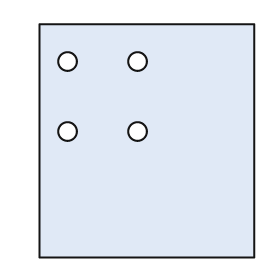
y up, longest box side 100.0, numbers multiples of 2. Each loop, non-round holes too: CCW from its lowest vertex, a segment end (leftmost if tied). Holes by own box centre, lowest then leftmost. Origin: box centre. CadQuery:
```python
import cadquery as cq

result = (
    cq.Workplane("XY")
    .moveTo(-46.0, -50.0)
    .lineTo(46.0, -50.0)
    .lineTo(46.0, 50.0)
    .lineTo(-46.0, 50.0)
    .close()
    .moveTo(-34.0, 4.0)
    .circle(4.0)
    .moveTo(-4.0, 4.0)
    .circle(4.0)
    .moveTo(-34.0, 34.0)
    .circle(4.0)
    .moveTo(-4.0, 34.0)
    .circle(4.0)
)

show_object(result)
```